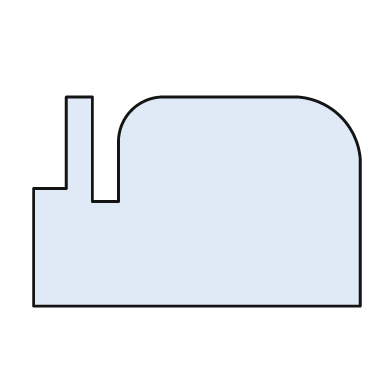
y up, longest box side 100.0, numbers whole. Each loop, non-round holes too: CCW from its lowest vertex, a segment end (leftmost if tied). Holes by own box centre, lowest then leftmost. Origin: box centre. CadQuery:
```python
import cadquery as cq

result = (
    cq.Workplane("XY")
    .moveTo(-50.0, -32.0)
    .lineTo(50.0, -32.0)
    .lineTo(50.0, 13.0)
    .threePointArc((44.0, 26.0), (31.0, 32.0))
    .lineTo(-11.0, 32.0)
    .threePointArc((-20.0, 28.0), (-24.0, 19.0))
    .lineTo(-24.0, 0.0)
    .lineTo(-32.0, 0.0)
    .lineTo(-32.0, 32.0)
    .lineTo(-40.0, 32.0)
    .lineTo(-40.0, 4.0)
    .lineTo(-50.0, 4.0)
    .close()
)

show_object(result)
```